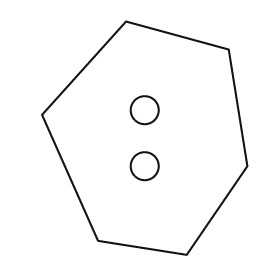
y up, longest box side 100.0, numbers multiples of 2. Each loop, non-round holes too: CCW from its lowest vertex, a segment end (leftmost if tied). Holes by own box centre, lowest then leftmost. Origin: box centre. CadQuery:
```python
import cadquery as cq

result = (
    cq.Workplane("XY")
    .moveTo(18.0, -50.0)
    .lineTo(44.0, -12.0)
    .lineTo(36.0, 38.0)
    .lineTo(-8.0, 50.0)
    .lineTo(-44.0, 10.0)
    .lineTo(-20.0, -44.0)
    .close()
    .moveTo(0.0, -12.0)
    .circle(6.0)
    .moveTo(0.0, 12.0)
    .circle(6.0)
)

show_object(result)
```